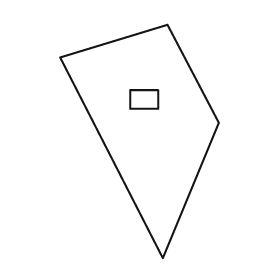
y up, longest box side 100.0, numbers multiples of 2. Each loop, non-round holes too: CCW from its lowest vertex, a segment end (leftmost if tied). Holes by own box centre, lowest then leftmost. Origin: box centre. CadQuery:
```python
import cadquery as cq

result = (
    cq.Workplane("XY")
    .moveTo(10.0, -50.0)
    .lineTo(34.0, 8.0)
    .lineTo(12.0, 50.0)
    .lineTo(-34.0, 36.0)
    .close()
    .moveTo(-4.0, 14.0)
    .lineTo(8.0, 14.0)
    .lineTo(8.0, 22.0)
    .lineTo(-4.0, 22.0)
    .close()
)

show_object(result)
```